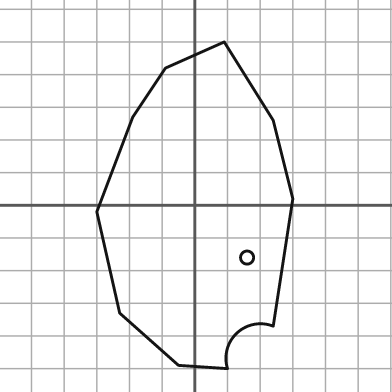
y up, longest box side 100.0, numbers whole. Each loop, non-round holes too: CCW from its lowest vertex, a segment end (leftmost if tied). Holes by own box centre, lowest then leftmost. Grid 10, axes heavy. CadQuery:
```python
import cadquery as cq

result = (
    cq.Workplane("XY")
    .moveTo(10.0, -50.0)
    .threePointArc((13.0, -39.0), (24.0, -37.0))
    .lineTo(30.0, 2.0)
    .lineTo(24.0, 26.0)
    .lineTo(9.0, 50.0)
    .lineTo(-9.0, 42.0)
    .lineTo(-19.0, 27.0)
    .lineTo(-30.0, -2.0)
    .lineTo(-23.0, -33.0)
    .lineTo(-5.0, -49.0)
    .close()
    .moveTo(16.0, -16.0)
    .circle(2.0)
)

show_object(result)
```